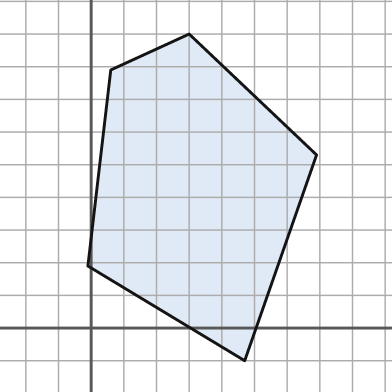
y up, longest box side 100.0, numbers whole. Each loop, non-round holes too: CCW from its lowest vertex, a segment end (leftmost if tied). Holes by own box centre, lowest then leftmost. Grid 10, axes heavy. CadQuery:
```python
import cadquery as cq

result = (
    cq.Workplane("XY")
    .moveTo(47.0, -10.0)
    .lineTo(69.0, 53.0)
    .lineTo(30.0, 90.0)
    .lineTo(6.0, 79.0)
    .lineTo(-1.0, 19.0)
    .close()
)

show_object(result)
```